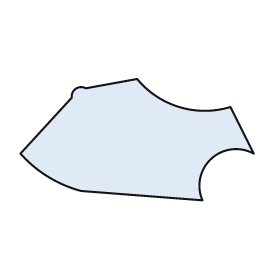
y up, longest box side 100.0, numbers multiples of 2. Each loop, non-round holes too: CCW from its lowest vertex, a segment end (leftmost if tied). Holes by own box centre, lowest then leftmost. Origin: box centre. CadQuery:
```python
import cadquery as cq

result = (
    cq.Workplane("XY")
    .moveTo(28.0, -26.0)
    .threePointArc((32.0, -8.0), (50.0, -6.0))
    .lineTo(40.0, 14.0)
    .threePointArc((18.0, 14.0), (0.0, 26.0))
    .lineTo(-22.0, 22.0)
    .threePointArc((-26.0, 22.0), (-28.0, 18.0))
    .lineTo(-50.0, -6.0)
    .threePointArc((-38.0, -16.0), (-24.0, -22.0))
    .close()
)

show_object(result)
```